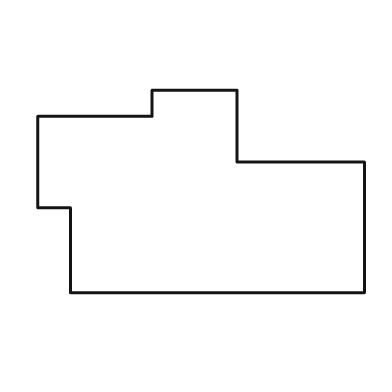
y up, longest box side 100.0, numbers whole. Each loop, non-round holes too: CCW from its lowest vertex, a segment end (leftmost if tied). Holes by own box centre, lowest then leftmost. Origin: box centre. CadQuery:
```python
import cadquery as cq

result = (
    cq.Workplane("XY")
    .moveTo(-40.0, -31.0)
    .lineTo(50.0, -31.0)
    .lineTo(50.0, 9.0)
    .lineTo(11.0, 9.0)
    .lineTo(11.0, 31.0)
    .lineTo(-15.0, 31.0)
    .lineTo(-15.0, 23.0)
    .lineTo(-50.0, 23.0)
    .lineTo(-50.0, -5.0)
    .lineTo(-40.0, -5.0)
    .close()
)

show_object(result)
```